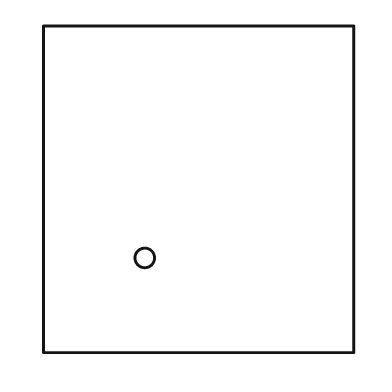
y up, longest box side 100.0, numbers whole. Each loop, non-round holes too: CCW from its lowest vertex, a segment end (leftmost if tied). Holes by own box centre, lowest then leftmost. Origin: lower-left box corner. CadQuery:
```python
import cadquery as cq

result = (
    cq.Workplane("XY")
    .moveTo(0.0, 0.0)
    .lineTo(95.0, 0.0)
    .lineTo(95.0, 100.0)
    .lineTo(0.0, 100.0)
    .close()
    .moveTo(31.0, 29.0)
    .circle(3.0)
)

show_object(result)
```